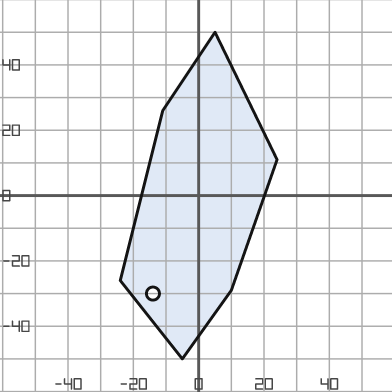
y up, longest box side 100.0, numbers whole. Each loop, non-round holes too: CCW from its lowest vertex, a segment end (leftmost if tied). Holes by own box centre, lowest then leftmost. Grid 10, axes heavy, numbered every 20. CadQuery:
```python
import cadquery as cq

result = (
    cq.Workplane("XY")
    .moveTo(-5.0, -50.0)
    .lineTo(10.0, -29.0)
    .lineTo(24.0, 11.0)
    .lineTo(5.0, 50.0)
    .lineTo(-11.0, 26.0)
    .lineTo(-24.0, -26.0)
    .close()
    .moveTo(-14.0, -30.0)
    .circle(2.0)
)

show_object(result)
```